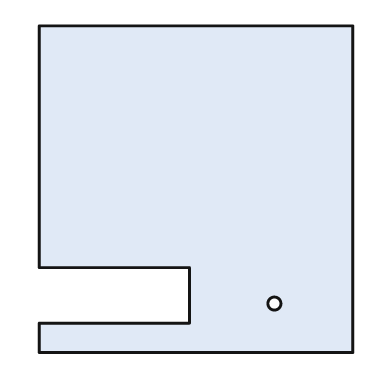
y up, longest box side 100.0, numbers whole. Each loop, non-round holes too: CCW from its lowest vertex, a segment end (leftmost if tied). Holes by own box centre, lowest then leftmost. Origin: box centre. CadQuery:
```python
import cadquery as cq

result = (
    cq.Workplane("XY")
    .moveTo(-48.0, -50.0)
    .lineTo(48.0, -50.0)
    .lineTo(48.0, 50.0)
    .lineTo(-48.0, 50.0)
    .lineTo(-48.0, -24.0)
    .lineTo(-2.0, -24.0)
    .lineTo(-2.0, -41.0)
    .lineTo(-48.0, -41.0)
    .close()
    .moveTo(24.0, -35.0)
    .circle(2.0)
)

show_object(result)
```